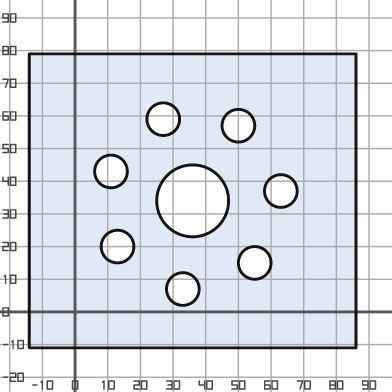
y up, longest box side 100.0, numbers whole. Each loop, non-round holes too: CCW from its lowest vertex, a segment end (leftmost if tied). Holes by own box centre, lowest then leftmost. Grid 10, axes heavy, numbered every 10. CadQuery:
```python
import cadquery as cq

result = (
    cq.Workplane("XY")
    .moveTo(-14.0, -11.0)
    .lineTo(86.0, -11.0)
    .lineTo(86.0, 79.0)
    .lineTo(-14.0, 79.0)
    .close()
    .moveTo(33.0, 7.0)
    .circle(5.0)
    .moveTo(55.0, 15.0)
    .circle(5.0)
    .moveTo(13.0, 20.0)
    .circle(5.0)
    .moveTo(36.0, 34.0)
    .circle(11.0)
    .moveTo(63.0, 37.0)
    .circle(5.0)
    .moveTo(11.0, 43.0)
    .circle(5.0)
    .moveTo(50.0, 57.0)
    .circle(5.0)
    .moveTo(27.0, 59.0)
    .circle(5.0)
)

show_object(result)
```